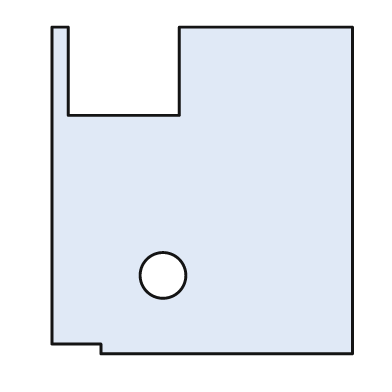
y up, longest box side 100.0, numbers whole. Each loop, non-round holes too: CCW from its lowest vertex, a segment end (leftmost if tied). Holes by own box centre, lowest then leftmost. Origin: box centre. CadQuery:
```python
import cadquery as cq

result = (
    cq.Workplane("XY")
    .moveTo(-31.0, -50.0)
    .lineTo(46.0, -50.0)
    .lineTo(46.0, 50.0)
    .lineTo(-7.0, 50.0)
    .lineTo(-7.0, 23.0)
    .lineTo(-41.0, 23.0)
    .lineTo(-41.0, 50.0)
    .lineTo(-46.0, 50.0)
    .lineTo(-46.0, -47.0)
    .lineTo(-31.0, -47.0)
    .close()
    .moveTo(-12.0, -26.0)
    .circle(7.0)
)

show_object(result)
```